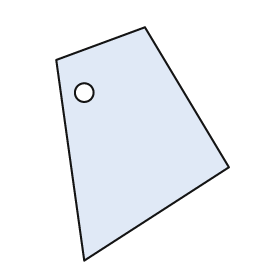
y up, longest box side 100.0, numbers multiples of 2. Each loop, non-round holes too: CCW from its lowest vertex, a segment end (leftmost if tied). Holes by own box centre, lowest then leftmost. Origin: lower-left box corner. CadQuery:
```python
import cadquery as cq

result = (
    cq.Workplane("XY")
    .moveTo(12.0, 0.0)
    .lineTo(74.0, 40.0)
    .lineTo(38.0, 100.0)
    .lineTo(0.0, 86.0)
    .close()
    .moveTo(12.0, 72.0)
    .circle(4.0)
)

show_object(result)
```